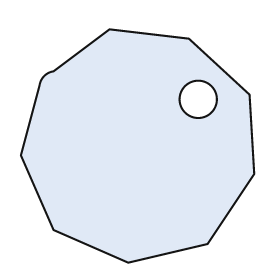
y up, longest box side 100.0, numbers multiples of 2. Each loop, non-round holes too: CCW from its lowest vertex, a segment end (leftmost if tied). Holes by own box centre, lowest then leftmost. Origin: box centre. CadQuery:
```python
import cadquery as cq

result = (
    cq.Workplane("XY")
    .moveTo(-4.0, -50.0)
    .lineTo(30.0, -42.0)
    .lineTo(50.0, -12.0)
    .lineTo(48.0, 22.0)
    .lineTo(22.0, 46.0)
    .lineTo(-12.0, 50.0)
    .lineTo(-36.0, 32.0)
    .threePointArc((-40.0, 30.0), (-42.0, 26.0))
    .lineTo(-50.0, -4.0)
    .lineTo(-36.0, -36.0)
    .close()
    .moveTo(26.0, 20.0)
    .circle(8.0)
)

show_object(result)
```